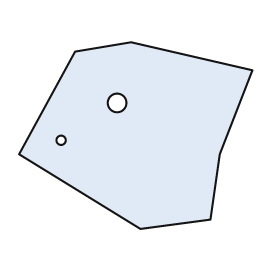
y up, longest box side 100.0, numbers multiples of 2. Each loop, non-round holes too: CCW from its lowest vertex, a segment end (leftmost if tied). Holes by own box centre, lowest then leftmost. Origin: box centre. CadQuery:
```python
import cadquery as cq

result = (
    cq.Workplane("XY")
    .moveTo(2.0, -40.0)
    .lineTo(32.0, -36.0)
    .lineTo(36.0, -8.0)
    .lineTo(50.0, 28.0)
    .lineTo(-2.0, 40.0)
    .lineTo(-26.0, 36.0)
    .lineTo(-50.0, -8.0)
    .close()
    .moveTo(-32.0, -2.0)
    .circle(2.0)
    .moveTo(-8.0, 14.0)
    .circle(4.0)
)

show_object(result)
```